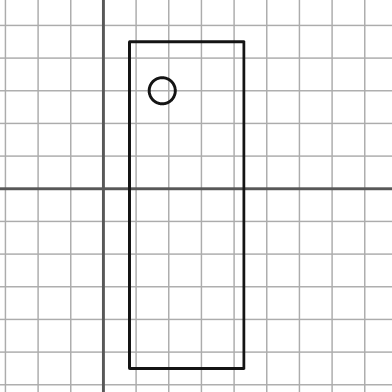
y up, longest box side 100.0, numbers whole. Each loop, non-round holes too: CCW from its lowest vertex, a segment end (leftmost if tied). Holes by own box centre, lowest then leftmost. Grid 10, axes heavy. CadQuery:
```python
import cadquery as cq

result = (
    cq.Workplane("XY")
    .moveTo(8.0, -55.0)
    .lineTo(43.0, -55.0)
    .lineTo(43.0, 45.0)
    .lineTo(8.0, 45.0)
    .close()
    .moveTo(18.0, 30.0)
    .circle(4.0)
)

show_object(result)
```